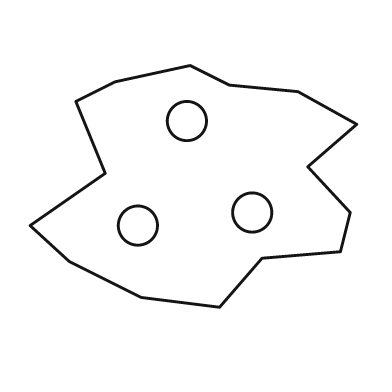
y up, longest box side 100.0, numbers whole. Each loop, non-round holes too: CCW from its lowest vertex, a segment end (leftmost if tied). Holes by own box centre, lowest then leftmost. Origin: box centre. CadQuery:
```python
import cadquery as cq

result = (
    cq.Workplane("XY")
    .moveTo(8.0, -37.0)
    .lineTo(21.0, -22.0)
    .lineTo(45.0, -20.0)
    .lineTo(48.0, -8.0)
    .lineTo(35.0, 6.0)
    .lineTo(50.0, 19.0)
    .lineTo(32.0, 29.0)
    .lineTo(11.0, 31.0)
    .lineTo(-1.0, 37.0)
    .lineTo(-24.0, 32.0)
    .lineTo(-36.0, 26.0)
    .lineTo(-27.0, 4.0)
    .lineTo(-50.0, -12.0)
    .lineTo(-38.0, -23.0)
    .lineTo(-16.0, -34.0)
    .close()
    .moveTo(-17.0, -12.0)
    .circle(6.0)
    .moveTo(18.0, -8.0)
    .circle(6.0)
    .moveTo(-2.0, 20.0)
    .circle(6.0)
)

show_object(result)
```